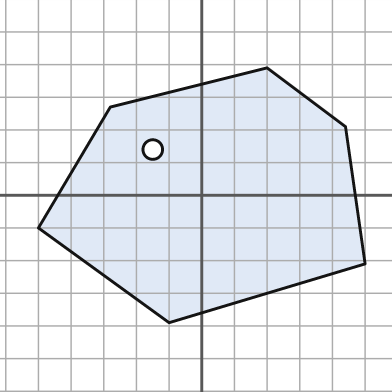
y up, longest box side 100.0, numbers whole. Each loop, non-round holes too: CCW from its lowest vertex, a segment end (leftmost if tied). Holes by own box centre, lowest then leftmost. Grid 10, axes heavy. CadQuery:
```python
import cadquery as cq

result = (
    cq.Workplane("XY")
    .moveTo(-10.0, -39.0)
    .lineTo(50.0, -21.0)
    .lineTo(44.0, 21.0)
    .lineTo(20.0, 39.0)
    .lineTo(-28.0, 27.0)
    .lineTo(-50.0, -10.0)
    .close()
    .moveTo(-15.0, 14.0)
    .circle(3.0)
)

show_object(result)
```